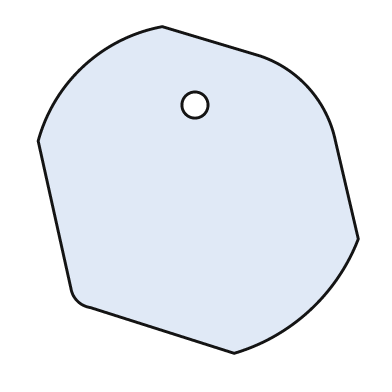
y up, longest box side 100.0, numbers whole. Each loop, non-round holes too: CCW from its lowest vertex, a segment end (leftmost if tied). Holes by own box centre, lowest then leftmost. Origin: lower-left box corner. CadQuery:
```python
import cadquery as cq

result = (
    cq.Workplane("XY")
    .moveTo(60.0, 0.0)
    .threePointArc((83.0, 13.0), (98.0, 35.0))
    .lineTo(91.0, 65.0)
    .threePointArc((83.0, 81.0), (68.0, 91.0))
    .lineTo(38.0, 100.0)
    .threePointArc((14.0, 88.0), (0.0, 65.0))
    .lineTo(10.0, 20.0)
    .threePointArc((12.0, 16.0), (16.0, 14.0))
    .close()
    .moveTo(48.0, 76.0)
    .circle(4.0)
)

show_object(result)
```